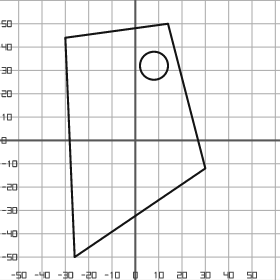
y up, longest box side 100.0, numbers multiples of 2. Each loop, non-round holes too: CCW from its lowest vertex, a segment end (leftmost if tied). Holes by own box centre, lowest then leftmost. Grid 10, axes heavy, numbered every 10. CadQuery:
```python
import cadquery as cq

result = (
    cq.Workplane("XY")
    .moveTo(-26.0, -50.0)
    .lineTo(30.0, -12.0)
    .lineTo(14.0, 50.0)
    .lineTo(-30.0, 44.0)
    .close()
    .moveTo(8.0, 32.0)
    .circle(6.0)
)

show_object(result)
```